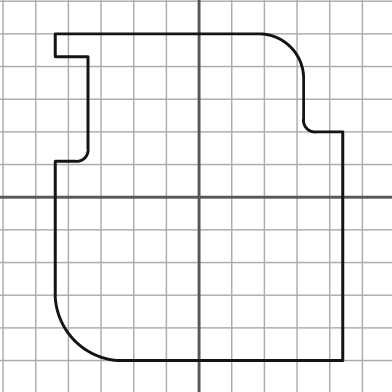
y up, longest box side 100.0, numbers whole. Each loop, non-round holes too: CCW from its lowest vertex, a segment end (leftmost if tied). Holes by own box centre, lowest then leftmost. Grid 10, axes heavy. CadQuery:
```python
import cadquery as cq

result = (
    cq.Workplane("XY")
    .moveTo(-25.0, -50.0)
    .lineTo(44.0, -50.0)
    .lineTo(44.0, 20.0)
    .lineTo(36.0, 20.0)
    .threePointArc((33.0, 21.0), (32.0, 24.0))
    .lineTo(32.0, 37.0)
    .threePointArc((28.0, 46.0), (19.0, 50.0))
    .lineTo(-44.0, 50.0)
    .lineTo(-44.0, 43.0)
    .lineTo(-34.0, 43.0)
    .lineTo(-34.0, 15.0)
    .threePointArc((-35.0, 12.0), (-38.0, 11.0))
    .lineTo(-44.0, 11.0)
    .lineTo(-44.0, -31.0)
    .threePointArc((-38.0, -44.0), (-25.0, -50.0))
    .close()
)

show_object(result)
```